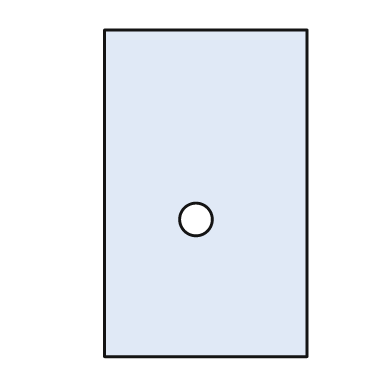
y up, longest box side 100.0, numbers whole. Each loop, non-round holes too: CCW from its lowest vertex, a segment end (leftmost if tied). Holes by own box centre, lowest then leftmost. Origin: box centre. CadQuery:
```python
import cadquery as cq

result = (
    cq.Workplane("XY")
    .moveTo(-31.0, -50.0)
    .lineTo(31.0, -50.0)
    .lineTo(31.0, 50.0)
    .lineTo(-31.0, 50.0)
    .close()
    .moveTo(-3.0, -8.0)
    .circle(5.0)
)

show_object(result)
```